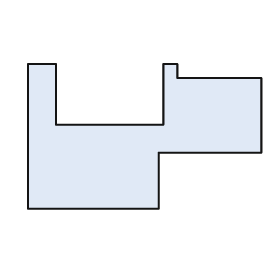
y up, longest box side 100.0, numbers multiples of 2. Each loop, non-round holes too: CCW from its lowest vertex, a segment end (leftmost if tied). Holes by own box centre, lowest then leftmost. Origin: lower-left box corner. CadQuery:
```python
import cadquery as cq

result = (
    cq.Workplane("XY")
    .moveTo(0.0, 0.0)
    .lineTo(56.0, 0.0)
    .lineTo(56.0, 24.0)
    .lineTo(100.0, 24.0)
    .lineTo(100.0, 56.0)
    .lineTo(64.0, 56.0)
    .lineTo(64.0, 62.0)
    .lineTo(58.0, 62.0)
    .lineTo(58.0, 36.0)
    .lineTo(12.0, 36.0)
    .lineTo(12.0, 62.0)
    .lineTo(0.0, 62.0)
    .close()
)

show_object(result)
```